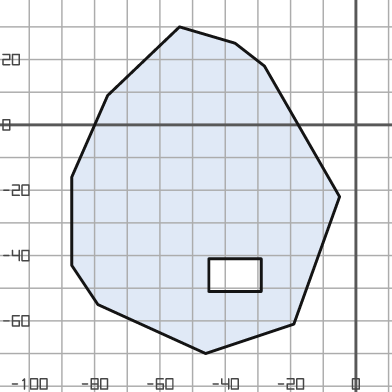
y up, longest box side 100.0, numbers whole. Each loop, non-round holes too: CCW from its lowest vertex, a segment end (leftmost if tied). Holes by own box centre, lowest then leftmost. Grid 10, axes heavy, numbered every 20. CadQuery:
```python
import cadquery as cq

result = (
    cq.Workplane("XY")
    .moveTo(-46.0, -70.0)
    .lineTo(-19.0, -61.0)
    .lineTo(-5.0, -22.0)
    .lineTo(-28.0, 18.0)
    .lineTo(-37.0, 25.0)
    .lineTo(-54.0, 30.0)
    .lineTo(-76.0, 9.0)
    .lineTo(-87.0, -16.0)
    .lineTo(-87.0, -43.0)
    .lineTo(-79.0, -55.0)
    .close()
    .moveTo(-45.0, -51.0)
    .lineTo(-29.0, -51.0)
    .lineTo(-29.0, -41.0)
    .lineTo(-45.0, -41.0)
    .close()
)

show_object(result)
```